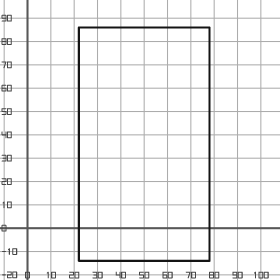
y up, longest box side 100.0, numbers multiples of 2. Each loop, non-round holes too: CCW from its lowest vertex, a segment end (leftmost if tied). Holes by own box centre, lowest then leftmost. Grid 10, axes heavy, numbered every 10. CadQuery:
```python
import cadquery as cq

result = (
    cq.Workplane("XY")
    .moveTo(22.0, -14.0)
    .lineTo(78.0, -14.0)
    .lineTo(78.0, 86.0)
    .lineTo(22.0, 86.0)
    .close()
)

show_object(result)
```